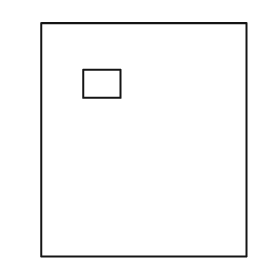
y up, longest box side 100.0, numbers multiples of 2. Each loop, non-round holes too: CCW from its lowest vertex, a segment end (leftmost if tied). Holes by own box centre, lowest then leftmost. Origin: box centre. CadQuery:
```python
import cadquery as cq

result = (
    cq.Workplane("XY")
    .moveTo(-44.0, -50.0)
    .lineTo(44.0, -50.0)
    .lineTo(44.0, 50.0)
    .lineTo(-44.0, 50.0)
    .close()
    .moveTo(-26.0, 18.0)
    .lineTo(-10.0, 18.0)
    .lineTo(-10.0, 30.0)
    .lineTo(-26.0, 30.0)
    .close()
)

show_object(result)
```